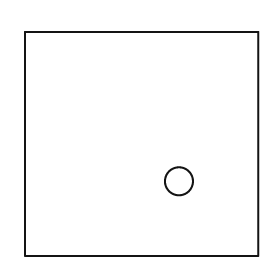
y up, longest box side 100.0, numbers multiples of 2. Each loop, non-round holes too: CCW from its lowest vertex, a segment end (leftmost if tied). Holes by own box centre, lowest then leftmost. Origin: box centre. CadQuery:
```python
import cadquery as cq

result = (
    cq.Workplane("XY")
    .moveTo(-50.0, -48.0)
    .lineTo(50.0, -48.0)
    .lineTo(50.0, 48.0)
    .lineTo(-50.0, 48.0)
    .close()
    .moveTo(16.0, -16.0)
    .circle(6.0)
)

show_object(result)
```